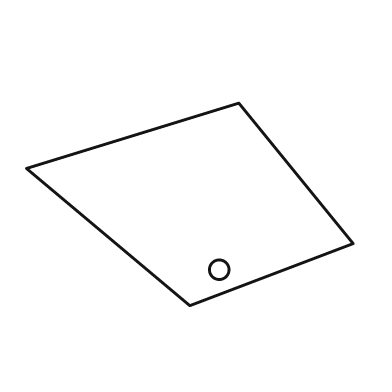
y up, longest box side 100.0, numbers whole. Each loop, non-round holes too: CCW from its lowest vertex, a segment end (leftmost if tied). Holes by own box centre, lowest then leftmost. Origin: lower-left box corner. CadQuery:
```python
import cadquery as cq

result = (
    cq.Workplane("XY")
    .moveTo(50.0, 0.0)
    .lineTo(100.0, 19.0)
    .lineTo(65.0, 62.0)
    .lineTo(0.0, 42.0)
    .close()
    .moveTo(59.0, 11.0)
    .circle(3.0)
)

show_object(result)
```